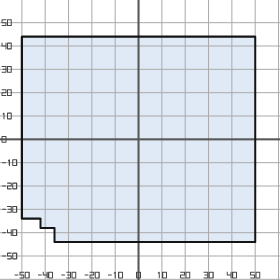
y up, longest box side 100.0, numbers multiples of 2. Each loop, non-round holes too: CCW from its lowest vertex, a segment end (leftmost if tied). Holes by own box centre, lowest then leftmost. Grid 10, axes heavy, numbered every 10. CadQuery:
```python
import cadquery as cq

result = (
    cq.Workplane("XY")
    .moveTo(-36.0, -44.0)
    .lineTo(50.0, -44.0)
    .lineTo(50.0, 44.0)
    .lineTo(-50.0, 44.0)
    .lineTo(-50.0, -34.0)
    .lineTo(-42.0, -34.0)
    .lineTo(-42.0, -38.0)
    .lineTo(-36.0, -38.0)
    .close()
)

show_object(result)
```